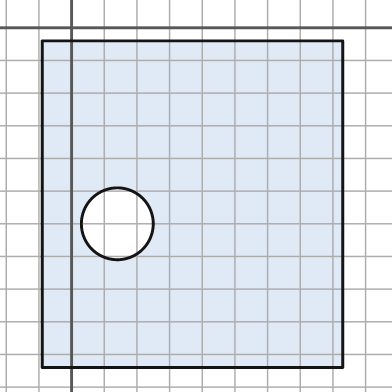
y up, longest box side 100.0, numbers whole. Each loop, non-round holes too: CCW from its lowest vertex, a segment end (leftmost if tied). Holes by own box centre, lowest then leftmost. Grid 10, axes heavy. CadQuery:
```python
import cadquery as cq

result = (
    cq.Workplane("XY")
    .moveTo(-9.0, -104.0)
    .lineTo(83.0, -104.0)
    .lineTo(83.0, -4.0)
    .lineTo(-9.0, -4.0)
    .close()
    .moveTo(14.0, -60.0)
    .circle(11.0)
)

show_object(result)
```